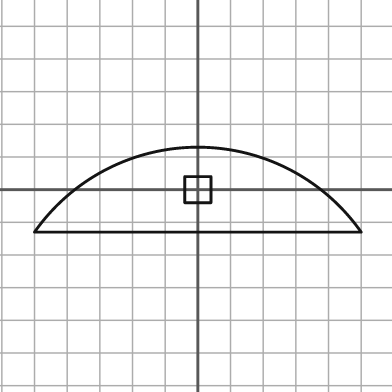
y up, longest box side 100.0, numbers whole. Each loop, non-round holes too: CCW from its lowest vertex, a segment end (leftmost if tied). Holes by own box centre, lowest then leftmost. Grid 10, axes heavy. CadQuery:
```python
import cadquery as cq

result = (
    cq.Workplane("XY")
    .moveTo(-50.0, -13.0)
    .lineTo(50.0, -13.0)
    .threePointArc((0.0, 13.0), (-50.0, -13.0))
    .close()
    .moveTo(-4.0, -4.0)
    .lineTo(4.0, -4.0)
    .lineTo(4.0, 4.0)
    .lineTo(-4.0, 4.0)
    .close()
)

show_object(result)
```